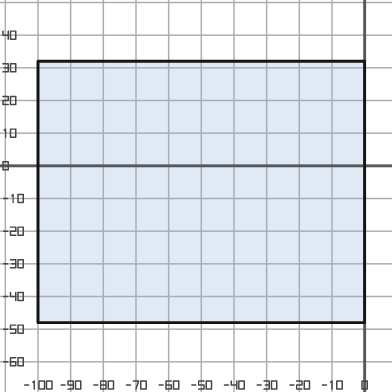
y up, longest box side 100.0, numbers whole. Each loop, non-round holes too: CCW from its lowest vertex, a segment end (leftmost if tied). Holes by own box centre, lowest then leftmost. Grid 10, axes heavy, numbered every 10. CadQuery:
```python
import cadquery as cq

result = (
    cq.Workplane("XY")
    .moveTo(-100.0, -48.0)
    .lineTo(0.0, -48.0)
    .lineTo(0.0, 32.0)
    .lineTo(-100.0, 32.0)
    .close()
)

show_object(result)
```